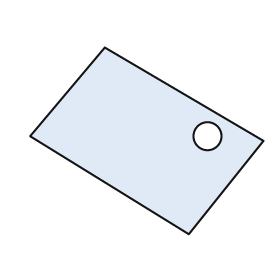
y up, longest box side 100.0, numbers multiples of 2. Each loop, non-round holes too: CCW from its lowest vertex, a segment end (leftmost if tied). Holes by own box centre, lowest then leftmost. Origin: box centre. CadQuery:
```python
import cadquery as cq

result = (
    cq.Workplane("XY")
    .moveTo(18.0, -40.0)
    .lineTo(50.0, 0.0)
    .lineTo(-18.0, 40.0)
    .lineTo(-50.0, 2.0)
    .close()
    .moveTo(26.0, 2.0)
    .circle(6.0)
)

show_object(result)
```